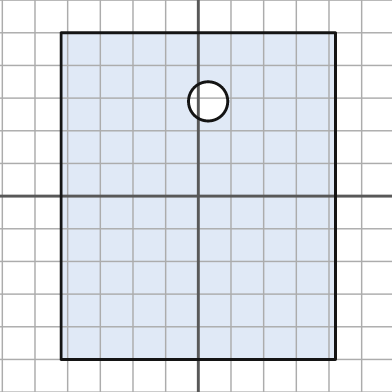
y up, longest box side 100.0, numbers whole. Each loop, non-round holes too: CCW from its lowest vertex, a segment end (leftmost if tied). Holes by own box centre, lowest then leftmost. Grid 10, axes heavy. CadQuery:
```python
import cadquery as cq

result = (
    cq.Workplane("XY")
    .moveTo(-42.0, -50.0)
    .lineTo(42.0, -50.0)
    .lineTo(42.0, 50.0)
    .lineTo(-42.0, 50.0)
    .close()
    .moveTo(3.0, 29.0)
    .circle(6.0)
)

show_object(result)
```